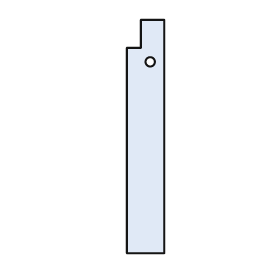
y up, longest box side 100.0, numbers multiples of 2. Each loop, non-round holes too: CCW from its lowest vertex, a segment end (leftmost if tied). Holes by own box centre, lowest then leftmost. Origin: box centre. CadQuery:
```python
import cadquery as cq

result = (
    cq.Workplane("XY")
    .moveTo(-8.0, -50.0)
    .lineTo(8.0, -50.0)
    .lineTo(8.0, 50.0)
    .lineTo(-2.0, 50.0)
    .lineTo(-2.0, 38.0)
    .lineTo(-8.0, 38.0)
    .close()
    .moveTo(2.0, 32.0)
    .circle(2.0)
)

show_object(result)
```